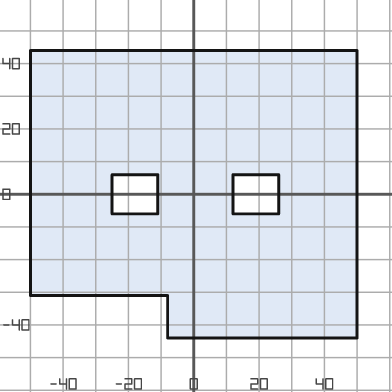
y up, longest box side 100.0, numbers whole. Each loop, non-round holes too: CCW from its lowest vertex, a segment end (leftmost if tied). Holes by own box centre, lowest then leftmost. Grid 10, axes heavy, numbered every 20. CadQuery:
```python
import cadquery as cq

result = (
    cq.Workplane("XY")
    .moveTo(-8.0, -44.0)
    .lineTo(50.0, -44.0)
    .lineTo(50.0, 44.0)
    .lineTo(-50.0, 44.0)
    .lineTo(-50.0, -31.0)
    .lineTo(-8.0, -31.0)
    .close()
    .moveTo(-25.0, -6.0)
    .lineTo(-11.0, -6.0)
    .lineTo(-11.0, 6.0)
    .lineTo(-25.0, 6.0)
    .close()
    .moveTo(12.0, -6.0)
    .lineTo(26.0, -6.0)
    .lineTo(26.0, 6.0)
    .lineTo(12.0, 6.0)
    .close()
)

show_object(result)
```